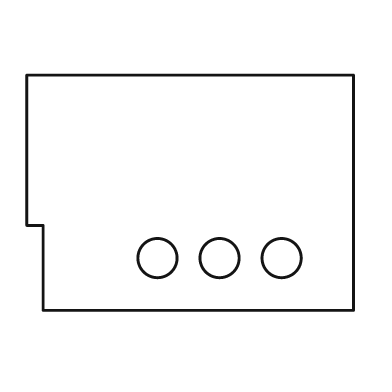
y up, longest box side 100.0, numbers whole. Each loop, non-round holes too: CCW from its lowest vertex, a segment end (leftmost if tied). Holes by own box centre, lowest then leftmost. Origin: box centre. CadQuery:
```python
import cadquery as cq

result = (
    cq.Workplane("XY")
    .moveTo(-45.0, -36.0)
    .lineTo(50.0, -36.0)
    .lineTo(50.0, 36.0)
    .lineTo(-50.0, 36.0)
    .lineTo(-50.0, -10.0)
    .lineTo(-45.0, -10.0)
    .close()
    .moveTo(-10.0, -20.0)
    .circle(6.0)
    .moveTo(9.0, -20.0)
    .circle(6.0)
    .moveTo(28.0, -20.0)
    .circle(6.0)
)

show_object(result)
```